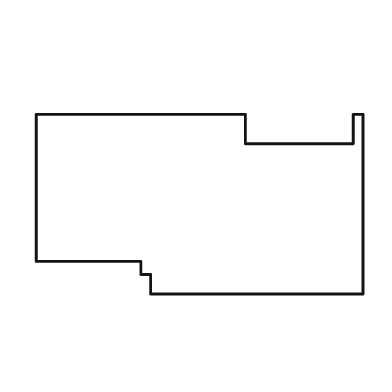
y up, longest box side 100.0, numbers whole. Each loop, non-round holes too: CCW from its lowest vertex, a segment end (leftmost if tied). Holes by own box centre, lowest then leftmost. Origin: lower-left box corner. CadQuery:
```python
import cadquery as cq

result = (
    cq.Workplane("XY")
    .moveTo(35.0, 0.0)
    .lineTo(100.0, 0.0)
    .lineTo(100.0, 55.0)
    .lineTo(97.0, 55.0)
    .lineTo(97.0, 46.0)
    .lineTo(64.0, 46.0)
    .lineTo(64.0, 55.0)
    .lineTo(0.0, 55.0)
    .lineTo(0.0, 10.0)
    .lineTo(32.0, 10.0)
    .lineTo(32.0, 6.0)
    .lineTo(35.0, 6.0)
    .close()
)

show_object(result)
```